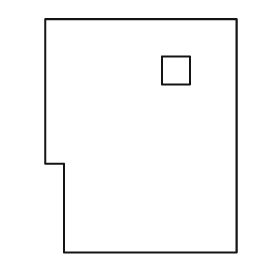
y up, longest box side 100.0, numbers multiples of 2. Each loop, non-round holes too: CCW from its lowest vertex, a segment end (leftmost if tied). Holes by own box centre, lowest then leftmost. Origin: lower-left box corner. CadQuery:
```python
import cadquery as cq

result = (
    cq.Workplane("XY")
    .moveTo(8.0, 0.0)
    .lineTo(82.0, 0.0)
    .lineTo(82.0, 100.0)
    .lineTo(0.0, 100.0)
    .lineTo(0.0, 38.0)
    .lineTo(8.0, 38.0)
    .close()
    .moveTo(50.0, 72.0)
    .lineTo(62.0, 72.0)
    .lineTo(62.0, 84.0)
    .lineTo(50.0, 84.0)
    .close()
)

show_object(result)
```